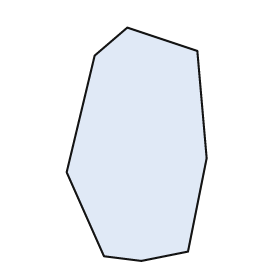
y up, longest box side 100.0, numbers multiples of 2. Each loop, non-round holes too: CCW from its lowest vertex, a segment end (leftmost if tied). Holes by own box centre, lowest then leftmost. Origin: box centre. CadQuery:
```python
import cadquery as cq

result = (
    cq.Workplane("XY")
    .moveTo(2.0, -50.0)
    .lineTo(22.0, -46.0)
    .lineTo(30.0, -6.0)
    .lineTo(26.0, 40.0)
    .lineTo(-4.0, 50.0)
    .lineTo(-18.0, 38.0)
    .lineTo(-30.0, -12.0)
    .lineTo(-14.0, -48.0)
    .close()
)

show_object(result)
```